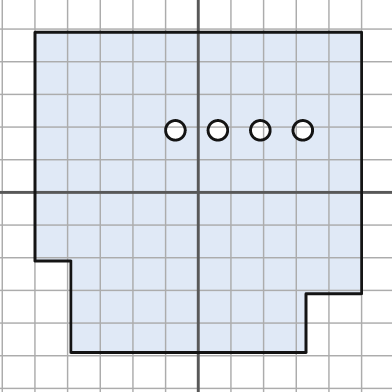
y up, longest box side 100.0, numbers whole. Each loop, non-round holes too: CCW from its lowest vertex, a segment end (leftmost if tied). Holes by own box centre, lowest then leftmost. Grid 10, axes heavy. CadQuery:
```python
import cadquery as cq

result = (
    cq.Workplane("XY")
    .moveTo(-39.0, -49.0)
    .lineTo(33.0, -49.0)
    .lineTo(33.0, -31.0)
    .lineTo(50.0, -31.0)
    .lineTo(50.0, 49.0)
    .lineTo(-50.0, 49.0)
    .lineTo(-50.0, -21.0)
    .lineTo(-39.0, -21.0)
    .close()
    .moveTo(-7.0, 19.0)
    .circle(3.0)
    .moveTo(6.0, 19.0)
    .circle(3.0)
    .moveTo(19.0, 19.0)
    .circle(3.0)
    .moveTo(32.0, 19.0)
    .circle(3.0)
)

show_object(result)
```